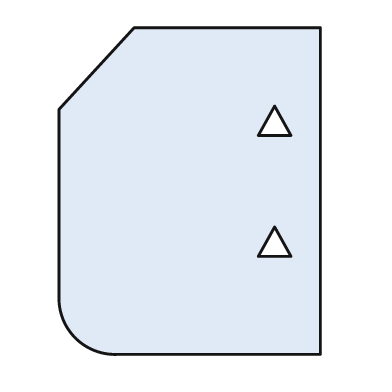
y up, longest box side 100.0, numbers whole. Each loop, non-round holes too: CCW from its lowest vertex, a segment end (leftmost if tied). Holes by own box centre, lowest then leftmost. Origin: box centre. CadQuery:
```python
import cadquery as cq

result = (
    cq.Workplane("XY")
    .moveTo(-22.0, -50.0)
    .lineTo(40.0, -50.0)
    .lineTo(40.0, 50.0)
    .lineTo(-17.0, 50.0)
    .lineTo(-40.0, 25.0)
    .lineTo(-40.0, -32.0)
    .threePointArc((-35.0, -45.0), (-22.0, -50.0))
    .close()
    .moveTo(21.0, -20.0)
    .lineTo(31.0, -20.0)
    .lineTo(26.0, -11.0)
    .close()
    .moveTo(21.0, 17.0)
    .lineTo(31.0, 17.0)
    .lineTo(26.0, 26.0)
    .close()
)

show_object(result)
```